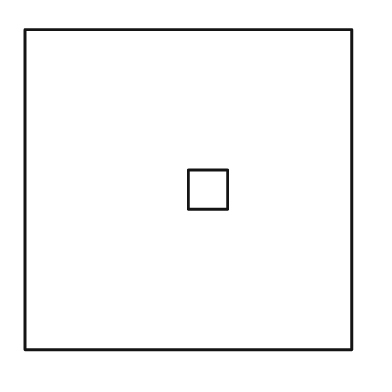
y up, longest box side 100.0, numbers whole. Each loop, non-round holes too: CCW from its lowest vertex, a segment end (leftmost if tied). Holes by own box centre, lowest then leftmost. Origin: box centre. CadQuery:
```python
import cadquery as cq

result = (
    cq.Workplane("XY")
    .moveTo(-50.0, -49.0)
    .lineTo(50.0, -49.0)
    .lineTo(50.0, 49.0)
    .lineTo(-50.0, 49.0)
    .close()
    .moveTo(0.0, -6.0)
    .lineTo(12.0, -6.0)
    .lineTo(12.0, 6.0)
    .lineTo(0.0, 6.0)
    .close()
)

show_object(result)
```